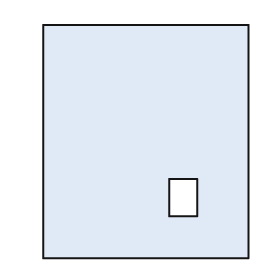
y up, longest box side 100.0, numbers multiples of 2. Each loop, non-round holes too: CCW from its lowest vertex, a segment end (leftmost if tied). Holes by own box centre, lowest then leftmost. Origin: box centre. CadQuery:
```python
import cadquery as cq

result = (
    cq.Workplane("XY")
    .moveTo(-44.0, -50.0)
    .lineTo(44.0, -50.0)
    .lineTo(44.0, 50.0)
    .lineTo(-44.0, 50.0)
    .close()
    .moveTo(10.0, -32.0)
    .lineTo(22.0, -32.0)
    .lineTo(22.0, -16.0)
    .lineTo(10.0, -16.0)
    .close()
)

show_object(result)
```